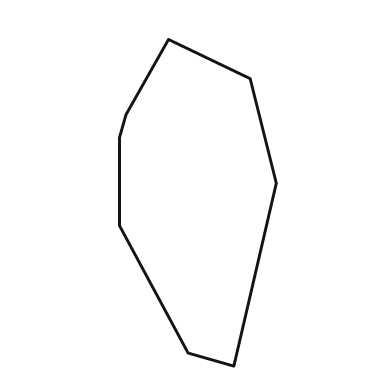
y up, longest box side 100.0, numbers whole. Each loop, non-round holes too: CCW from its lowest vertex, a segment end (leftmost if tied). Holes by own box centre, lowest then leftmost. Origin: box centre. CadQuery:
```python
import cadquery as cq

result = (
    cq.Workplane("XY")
    .moveTo(11.0, -50.0)
    .lineTo(24.0, 6.0)
    .lineTo(16.0, 38.0)
    .lineTo(-9.0, 50.0)
    .lineTo(-22.0, 27.0)
    .lineTo(-24.0, 20.0)
    .lineTo(-24.0, -7.0)
    .lineTo(-3.0, -46.0)
    .close()
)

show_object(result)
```